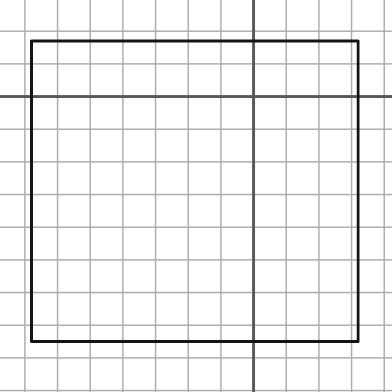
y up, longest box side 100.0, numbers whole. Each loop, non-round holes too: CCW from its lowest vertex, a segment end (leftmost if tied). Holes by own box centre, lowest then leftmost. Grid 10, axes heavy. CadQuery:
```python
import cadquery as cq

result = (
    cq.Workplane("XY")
    .moveTo(-68.0, -75.0)
    .lineTo(32.0, -75.0)
    .lineTo(32.0, 17.0)
    .lineTo(-68.0, 17.0)
    .close()
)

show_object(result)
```